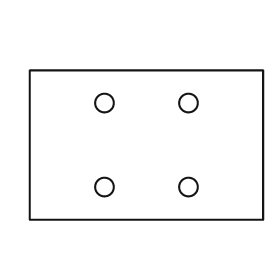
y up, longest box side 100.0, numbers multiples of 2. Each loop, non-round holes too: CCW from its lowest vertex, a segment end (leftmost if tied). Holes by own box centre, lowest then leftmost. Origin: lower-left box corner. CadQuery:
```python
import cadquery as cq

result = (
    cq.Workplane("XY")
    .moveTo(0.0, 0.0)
    .lineTo(100.0, 0.0)
    .lineTo(100.0, 64.0)
    .lineTo(0.0, 64.0)
    .close()
    .moveTo(32.0, 14.0)
    .circle(4.0)
    .moveTo(68.0, 14.0)
    .circle(4.0)
    .moveTo(32.0, 50.0)
    .circle(4.0)
    .moveTo(68.0, 50.0)
    .circle(4.0)
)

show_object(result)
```